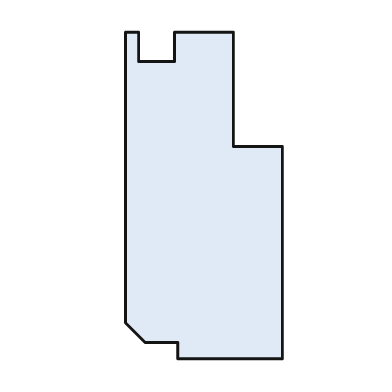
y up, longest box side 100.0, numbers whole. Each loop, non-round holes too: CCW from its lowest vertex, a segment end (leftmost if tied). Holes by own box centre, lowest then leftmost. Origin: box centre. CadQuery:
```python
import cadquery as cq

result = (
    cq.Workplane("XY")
    .moveTo(-8.0, -50.0)
    .lineTo(24.0, -50.0)
    .lineTo(24.0, 15.0)
    .lineTo(9.0, 15.0)
    .lineTo(9.0, 50.0)
    .lineTo(-9.0, 50.0)
    .lineTo(-9.0, 41.0)
    .lineTo(-20.0, 41.0)
    .lineTo(-20.0, 50.0)
    .lineTo(-24.0, 50.0)
    .lineTo(-24.0, -39.0)
    .lineTo(-18.0, -45.0)
    .lineTo(-8.0, -45.0)
    .close()
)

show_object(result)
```